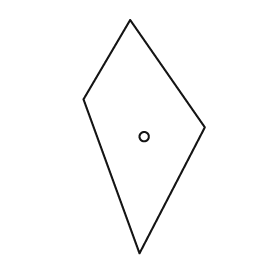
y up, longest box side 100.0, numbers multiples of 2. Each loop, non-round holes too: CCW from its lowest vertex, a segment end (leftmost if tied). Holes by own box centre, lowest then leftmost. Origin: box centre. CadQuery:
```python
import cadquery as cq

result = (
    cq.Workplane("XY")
    .moveTo(-2.0, -50.0)
    .lineTo(26.0, 4.0)
    .lineTo(-6.0, 50.0)
    .lineTo(-26.0, 16.0)
    .close()
    .moveTo(0.0, 0.0)
    .circle(2.0)
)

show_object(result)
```